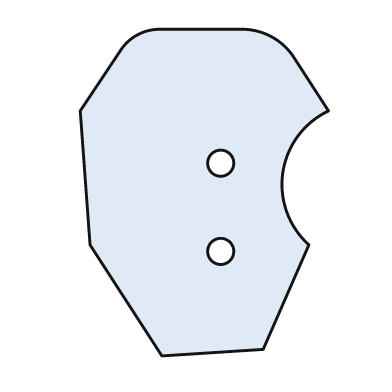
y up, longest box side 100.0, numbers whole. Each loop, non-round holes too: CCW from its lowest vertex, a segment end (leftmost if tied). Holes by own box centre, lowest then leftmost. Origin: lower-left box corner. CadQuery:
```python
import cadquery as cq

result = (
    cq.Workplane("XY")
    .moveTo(25.0, 0.0)
    .lineTo(56.0, 2.0)
    .lineTo(70.0, 34.0)
    .threePointArc((62.0, 56.0), (76.0, 75.0))
    .lineTo(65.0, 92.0)
    .threePointArc((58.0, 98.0), (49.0, 100.0))
    .lineTo(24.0, 100.0)
    .threePointArc((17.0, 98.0), (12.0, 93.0))
    .lineTo(0.0, 75.0)
    .lineTo(3.0, 34.0)
    .close()
    .moveTo(43.0, 32.0)
    .circle(4.0)
    .moveTo(43.0, 59.0)
    .circle(4.0)
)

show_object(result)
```